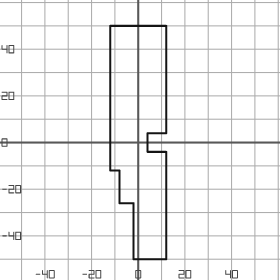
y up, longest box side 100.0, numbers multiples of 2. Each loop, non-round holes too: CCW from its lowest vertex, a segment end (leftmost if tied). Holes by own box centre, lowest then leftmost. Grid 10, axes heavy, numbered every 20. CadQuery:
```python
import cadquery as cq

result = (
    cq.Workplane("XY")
    .moveTo(-2.0, -50.0)
    .lineTo(12.0, -50.0)
    .lineTo(12.0, -4.0)
    .lineTo(4.0, -4.0)
    .lineTo(4.0, 4.0)
    .lineTo(12.0, 4.0)
    .lineTo(12.0, 50.0)
    .lineTo(-12.0, 50.0)
    .lineTo(-12.0, -12.0)
    .lineTo(-8.0, -12.0)
    .lineTo(-8.0, -26.0)
    .lineTo(-2.0, -26.0)
    .close()
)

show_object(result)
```